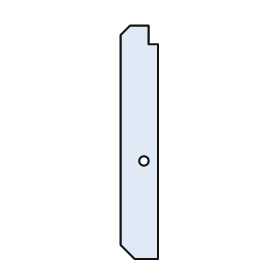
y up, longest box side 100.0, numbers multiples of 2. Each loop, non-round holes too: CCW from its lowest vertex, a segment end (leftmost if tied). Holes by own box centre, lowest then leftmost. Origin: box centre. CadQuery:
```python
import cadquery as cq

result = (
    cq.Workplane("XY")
    .moveTo(-2.0, -50.0)
    .lineTo(8.0, -50.0)
    .lineTo(8.0, 42.0)
    .lineTo(4.0, 42.0)
    .lineTo(4.0, 50.0)
    .lineTo(-4.0, 50.0)
    .lineTo(-8.0, 46.0)
    .lineTo(-8.0, -44.0)
    .close()
    .moveTo(2.0, -8.0)
    .circle(2.0)
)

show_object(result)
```